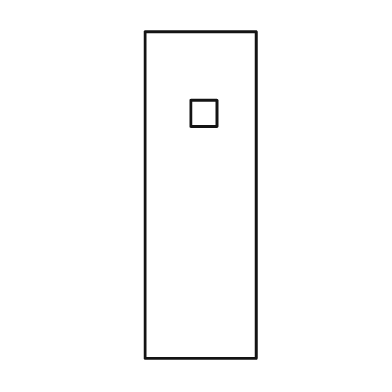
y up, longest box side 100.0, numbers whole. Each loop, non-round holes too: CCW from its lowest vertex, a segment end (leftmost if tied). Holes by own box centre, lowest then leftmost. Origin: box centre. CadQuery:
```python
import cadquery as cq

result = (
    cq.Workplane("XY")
    .moveTo(-17.0, -50.0)
    .lineTo(17.0, -50.0)
    .lineTo(17.0, 50.0)
    .lineTo(-17.0, 50.0)
    .close()
    .moveTo(-3.0, 21.0)
    .lineTo(5.0, 21.0)
    .lineTo(5.0, 29.0)
    .lineTo(-3.0, 29.0)
    .close()
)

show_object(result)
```